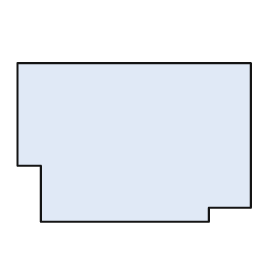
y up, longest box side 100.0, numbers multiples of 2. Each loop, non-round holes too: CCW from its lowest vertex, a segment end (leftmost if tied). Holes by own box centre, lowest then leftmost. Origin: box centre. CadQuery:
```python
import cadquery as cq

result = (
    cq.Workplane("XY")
    .moveTo(-40.0, -34.0)
    .lineTo(32.0, -34.0)
    .lineTo(32.0, -28.0)
    .lineTo(50.0, -28.0)
    .lineTo(50.0, 34.0)
    .lineTo(-50.0, 34.0)
    .lineTo(-50.0, -10.0)
    .lineTo(-40.0, -10.0)
    .close()
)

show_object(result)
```